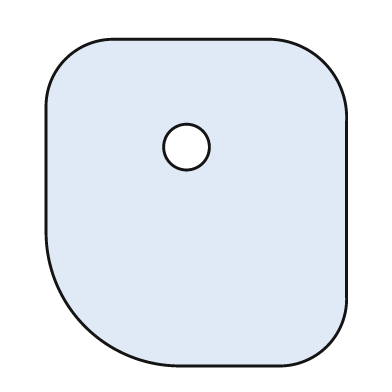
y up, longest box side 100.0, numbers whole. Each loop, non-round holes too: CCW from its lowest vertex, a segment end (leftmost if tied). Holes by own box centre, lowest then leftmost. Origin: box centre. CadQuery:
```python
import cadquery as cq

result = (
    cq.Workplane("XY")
    .moveTo(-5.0, -50.0)
    .lineTo(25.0, -50.0)
    .threePointArc((40.0, -44.0), (46.0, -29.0))
    .lineTo(46.0, 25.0)
    .threePointArc((39.0, 43.0), (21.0, 50.0))
    .lineTo(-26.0, 50.0)
    .threePointArc((-40.0, 44.0), (-46.0, 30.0))
    .lineTo(-46.0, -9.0)
    .threePointArc((-34.0, -38.0), (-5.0, -50.0))
    .close()
    .moveTo(-3.0, 17.0)
    .circle(7.0)
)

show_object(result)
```